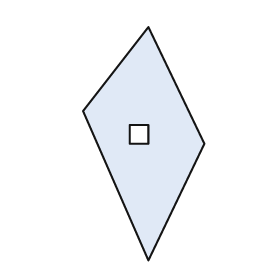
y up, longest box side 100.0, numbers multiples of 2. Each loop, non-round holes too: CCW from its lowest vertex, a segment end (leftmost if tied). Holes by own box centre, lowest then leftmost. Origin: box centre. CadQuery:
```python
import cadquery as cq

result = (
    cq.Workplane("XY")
    .moveTo(2.0, -50.0)
    .lineTo(26.0, 0.0)
    .lineTo(2.0, 50.0)
    .lineTo(-26.0, 14.0)
    .close()
    .moveTo(-6.0, 0.0)
    .lineTo(2.0, 0.0)
    .lineTo(2.0, 8.0)
    .lineTo(-6.0, 8.0)
    .close()
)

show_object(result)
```